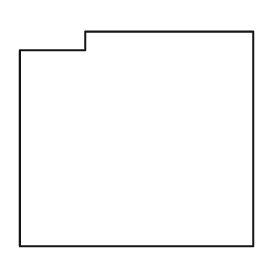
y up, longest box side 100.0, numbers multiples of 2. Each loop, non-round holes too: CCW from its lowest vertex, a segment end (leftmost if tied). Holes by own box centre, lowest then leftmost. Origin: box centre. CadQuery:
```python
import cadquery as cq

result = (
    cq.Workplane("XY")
    .moveTo(-50.0, -46.0)
    .lineTo(50.0, -46.0)
    .lineTo(50.0, 46.0)
    .lineTo(-22.0, 46.0)
    .lineTo(-22.0, 38.0)
    .lineTo(-50.0, 38.0)
    .close()
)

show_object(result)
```